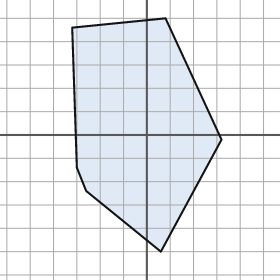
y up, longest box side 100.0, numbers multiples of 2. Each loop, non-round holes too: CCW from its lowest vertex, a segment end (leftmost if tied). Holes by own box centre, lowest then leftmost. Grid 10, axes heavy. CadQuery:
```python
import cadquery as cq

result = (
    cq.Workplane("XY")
    .moveTo(6.0, -50.0)
    .lineTo(32.0, -2.0)
    .lineTo(8.0, 50.0)
    .lineTo(-32.0, 46.0)
    .lineTo(-30.0, -14.0)
    .lineTo(-26.0, -24.0)
    .close()
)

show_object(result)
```